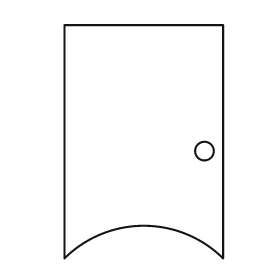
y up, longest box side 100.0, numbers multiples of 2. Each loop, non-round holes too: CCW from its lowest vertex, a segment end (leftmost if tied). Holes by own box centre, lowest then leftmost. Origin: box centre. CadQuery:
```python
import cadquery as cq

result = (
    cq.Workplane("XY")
    .moveTo(-34.0, -50.0)
    .threePointArc((0.0, -36.0), (34.0, -50.0))
    .lineTo(34.0, 50.0)
    .lineTo(-34.0, 50.0)
    .close()
    .moveTo(26.0, -4.0)
    .circle(4.0)
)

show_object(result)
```